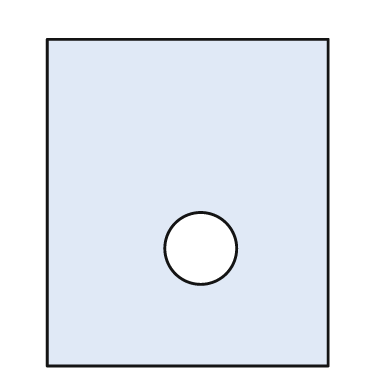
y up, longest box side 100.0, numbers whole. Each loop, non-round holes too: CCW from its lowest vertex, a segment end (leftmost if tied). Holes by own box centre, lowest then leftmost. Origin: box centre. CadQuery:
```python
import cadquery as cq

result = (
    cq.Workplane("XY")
    .moveTo(-43.0, -50.0)
    .lineTo(43.0, -50.0)
    .lineTo(43.0, 50.0)
    .lineTo(-43.0, 50.0)
    .close()
    .moveTo(4.0, -14.0)
    .circle(11.0)
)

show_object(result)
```